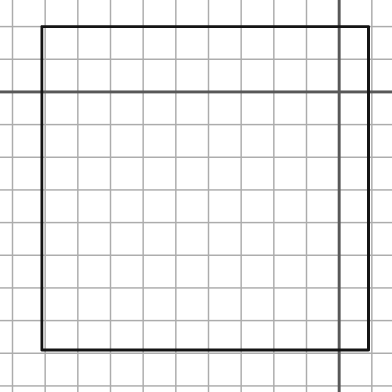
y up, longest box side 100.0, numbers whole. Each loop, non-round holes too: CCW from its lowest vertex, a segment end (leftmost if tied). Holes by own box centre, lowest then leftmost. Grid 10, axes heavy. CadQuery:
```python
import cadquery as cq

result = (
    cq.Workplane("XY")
    .moveTo(-91.0, -79.0)
    .lineTo(9.0, -79.0)
    .lineTo(9.0, 20.0)
    .lineTo(-91.0, 20.0)
    .close()
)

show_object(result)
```